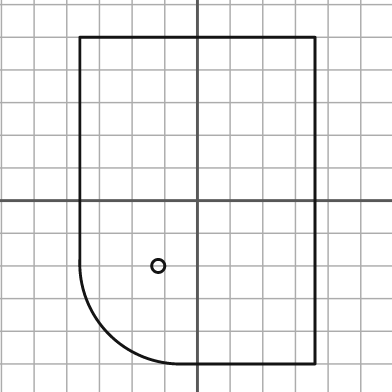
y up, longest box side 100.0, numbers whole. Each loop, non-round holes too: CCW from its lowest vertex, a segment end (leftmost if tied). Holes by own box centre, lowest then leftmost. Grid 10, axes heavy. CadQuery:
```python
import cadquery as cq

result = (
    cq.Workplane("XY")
    .moveTo(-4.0, -50.0)
    .lineTo(36.0, -50.0)
    .lineTo(36.0, 50.0)
    .lineTo(-36.0, 50.0)
    .lineTo(-36.0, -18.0)
    .threePointArc((-27.0, -41.0), (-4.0, -50.0))
    .close()
    .moveTo(-12.0, -20.0)
    .circle(2.0)
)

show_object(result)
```